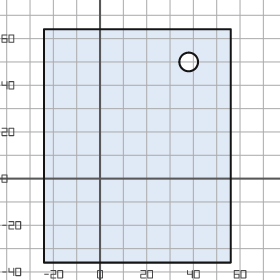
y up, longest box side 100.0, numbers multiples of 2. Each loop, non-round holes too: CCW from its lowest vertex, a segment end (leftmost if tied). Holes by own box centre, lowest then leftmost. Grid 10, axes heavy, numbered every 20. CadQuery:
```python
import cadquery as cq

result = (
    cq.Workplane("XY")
    .moveTo(-24.0, -36.0)
    .lineTo(56.0, -36.0)
    .lineTo(56.0, 64.0)
    .lineTo(-24.0, 64.0)
    .close()
    .moveTo(38.0, 50.0)
    .circle(4.0)
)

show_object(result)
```